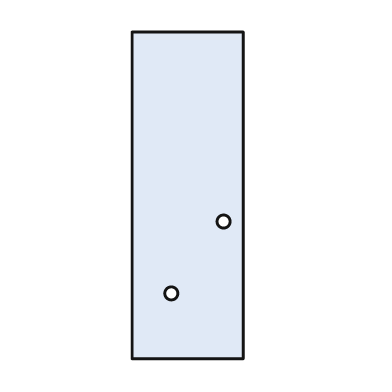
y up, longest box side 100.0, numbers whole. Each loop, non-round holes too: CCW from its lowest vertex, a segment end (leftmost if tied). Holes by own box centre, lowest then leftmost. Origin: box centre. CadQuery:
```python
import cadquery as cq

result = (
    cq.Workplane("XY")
    .moveTo(-17.0, -50.0)
    .lineTo(17.0, -50.0)
    .lineTo(17.0, 50.0)
    .lineTo(-17.0, 50.0)
    .close()
    .moveTo(-5.0, -30.0)
    .circle(2.0)
    .moveTo(11.0, -8.0)
    .circle(2.0)
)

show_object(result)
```